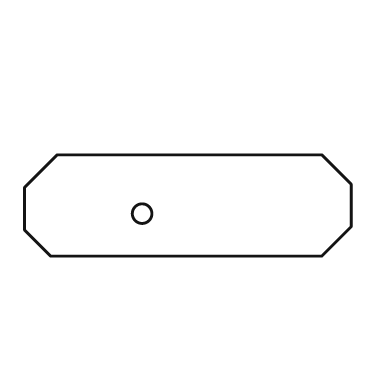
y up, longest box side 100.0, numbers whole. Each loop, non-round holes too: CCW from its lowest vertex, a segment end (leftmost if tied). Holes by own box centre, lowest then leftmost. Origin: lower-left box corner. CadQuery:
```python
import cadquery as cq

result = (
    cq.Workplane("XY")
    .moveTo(8.0, 0.0)
    .lineTo(91.0, 0.0)
    .lineTo(100.0, 9.0)
    .lineTo(100.0, 22.0)
    .lineTo(91.0, 31.0)
    .lineTo(10.0, 31.0)
    .lineTo(0.0, 21.0)
    .lineTo(0.0, 8.0)
    .close()
    .moveTo(36.0, 13.0)
    .circle(3.0)
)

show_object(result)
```